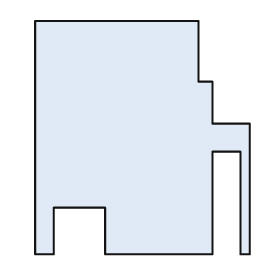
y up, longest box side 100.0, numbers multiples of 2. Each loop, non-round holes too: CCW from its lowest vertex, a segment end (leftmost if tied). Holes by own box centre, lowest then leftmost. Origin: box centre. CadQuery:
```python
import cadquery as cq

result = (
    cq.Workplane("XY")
    .moveTo(-46.0, -50.0)
    .lineTo(-38.0, -50.0)
    .lineTo(-38.0, -30.0)
    .lineTo(-16.0, -30.0)
    .lineTo(-16.0, -50.0)
    .lineTo(30.0, -50.0)
    .lineTo(30.0, -6.0)
    .lineTo(42.0, -6.0)
    .lineTo(42.0, -50.0)
    .lineTo(46.0, -50.0)
    .lineTo(46.0, 6.0)
    .lineTo(30.0, 6.0)
    .lineTo(30.0, 24.0)
    .lineTo(24.0, 24.0)
    .lineTo(24.0, 50.0)
    .lineTo(-46.0, 50.0)
    .close()
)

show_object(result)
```